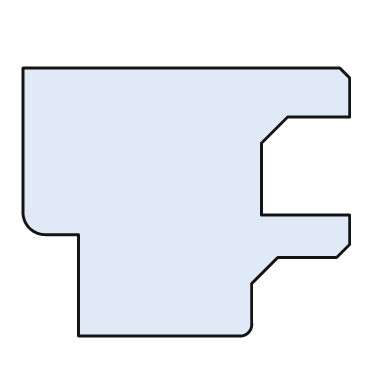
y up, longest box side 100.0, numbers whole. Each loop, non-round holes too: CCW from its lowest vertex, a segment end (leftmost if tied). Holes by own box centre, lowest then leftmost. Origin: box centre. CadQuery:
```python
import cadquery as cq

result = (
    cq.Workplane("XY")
    .moveTo(-33.0, -41.0)
    .lineTo(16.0, -41.0)
    .threePointArc((19.0, -40.0), (20.0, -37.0))
    .lineTo(20.0, -25.0)
    .lineTo(28.0, -17.0)
    .lineTo(46.0, -17.0)
    .lineTo(50.0, -13.0)
    .lineTo(50.0, -4.0)
    .lineTo(23.0, -4.0)
    .lineTo(23.0, 18.0)
    .lineTo(31.0, 26.0)
    .lineTo(50.0, 26.0)
    .lineTo(50.0, 38.0)
    .lineTo(47.0, 41.0)
    .lineTo(-50.0, 41.0)
    .lineTo(-50.0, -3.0)
    .threePointArc((-48.0, -8.0), (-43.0, -10.0))
    .lineTo(-33.0, -10.0)
    .close()
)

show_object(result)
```